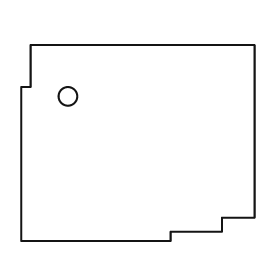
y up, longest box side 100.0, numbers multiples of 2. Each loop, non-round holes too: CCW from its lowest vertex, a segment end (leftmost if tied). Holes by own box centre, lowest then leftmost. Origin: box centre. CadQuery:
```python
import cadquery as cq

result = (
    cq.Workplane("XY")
    .moveTo(-50.0, -42.0)
    .lineTo(14.0, -42.0)
    .lineTo(14.0, -38.0)
    .lineTo(36.0, -38.0)
    .lineTo(36.0, -32.0)
    .lineTo(50.0, -32.0)
    .lineTo(50.0, 42.0)
    .lineTo(-46.0, 42.0)
    .lineTo(-46.0, 24.0)
    .lineTo(-50.0, 24.0)
    .close()
    .moveTo(-30.0, 20.0)
    .circle(4.0)
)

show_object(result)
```